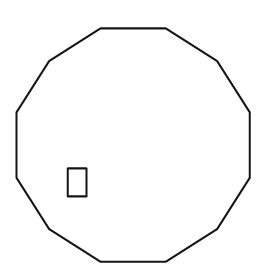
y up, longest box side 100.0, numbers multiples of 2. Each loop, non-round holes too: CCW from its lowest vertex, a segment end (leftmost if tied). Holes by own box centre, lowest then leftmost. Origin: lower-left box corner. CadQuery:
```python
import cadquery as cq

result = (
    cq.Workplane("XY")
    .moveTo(36.0, 0.0)
    .lineTo(64.0, 0.0)
    .lineTo(86.0, 14.0)
    .lineTo(100.0, 36.0)
    .lineTo(100.0, 64.0)
    .lineTo(86.0, 86.0)
    .lineTo(64.0, 100.0)
    .lineTo(36.0, 100.0)
    .lineTo(14.0, 86.0)
    .lineTo(0.0, 64.0)
    .lineTo(0.0, 36.0)
    .lineTo(14.0, 14.0)
    .close()
    .moveTo(22.0, 28.0)
    .lineTo(30.0, 28.0)
    .lineTo(30.0, 40.0)
    .lineTo(22.0, 40.0)
    .close()
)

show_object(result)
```